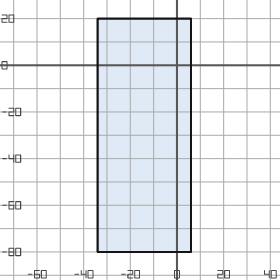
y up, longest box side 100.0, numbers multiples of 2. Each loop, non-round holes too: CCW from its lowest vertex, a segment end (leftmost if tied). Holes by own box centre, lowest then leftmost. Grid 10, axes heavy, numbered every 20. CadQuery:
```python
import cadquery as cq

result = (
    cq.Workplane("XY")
    .moveTo(-34.0, -80.0)
    .lineTo(6.0, -80.0)
    .lineTo(6.0, 20.0)
    .lineTo(-34.0, 20.0)
    .close()
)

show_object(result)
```